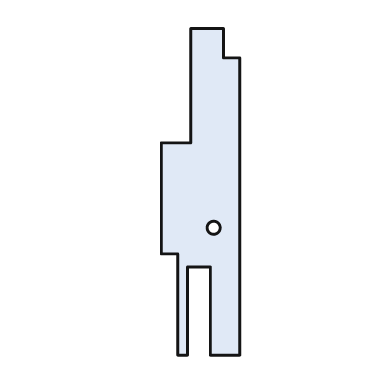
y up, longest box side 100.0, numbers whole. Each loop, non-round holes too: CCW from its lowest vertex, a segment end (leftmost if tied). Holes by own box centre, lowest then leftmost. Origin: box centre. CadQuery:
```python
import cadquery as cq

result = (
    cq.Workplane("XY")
    .moveTo(-7.0, -50.0)
    .lineTo(-4.0, -50.0)
    .lineTo(-4.0, -23.0)
    .lineTo(3.0, -23.0)
    .lineTo(3.0, -50.0)
    .lineTo(12.0, -50.0)
    .lineTo(12.0, 41.0)
    .lineTo(7.0, 41.0)
    .lineTo(7.0, 50.0)
    .lineTo(-3.0, 50.0)
    .lineTo(-3.0, 15.0)
    .lineTo(-12.0, 15.0)
    .lineTo(-12.0, -19.0)
    .lineTo(-7.0, -19.0)
    .close()
    .moveTo(4.0, -11.0)
    .circle(2.0)
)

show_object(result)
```